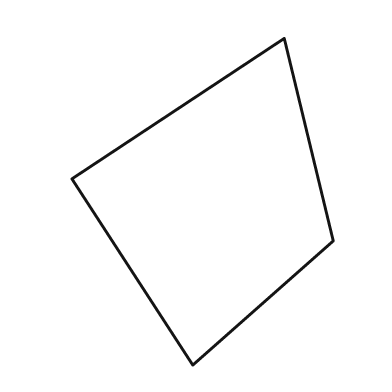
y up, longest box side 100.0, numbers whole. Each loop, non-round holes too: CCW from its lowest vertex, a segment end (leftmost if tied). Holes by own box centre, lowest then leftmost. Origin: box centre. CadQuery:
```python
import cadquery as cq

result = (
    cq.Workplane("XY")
    .moveTo(-3.0, -50.0)
    .lineTo(40.0, -12.0)
    .lineTo(25.0, 50.0)
    .lineTo(-40.0, 7.0)
    .close()
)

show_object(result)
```